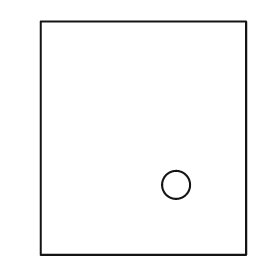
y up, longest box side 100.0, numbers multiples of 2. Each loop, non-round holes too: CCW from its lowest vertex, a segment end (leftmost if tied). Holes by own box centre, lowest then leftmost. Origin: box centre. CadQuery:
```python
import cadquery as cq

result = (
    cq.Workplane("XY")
    .moveTo(-44.0, -50.0)
    .lineTo(44.0, -50.0)
    .lineTo(44.0, 50.0)
    .lineTo(-44.0, 50.0)
    .close()
    .moveTo(14.0, -20.0)
    .circle(6.0)
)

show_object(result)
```